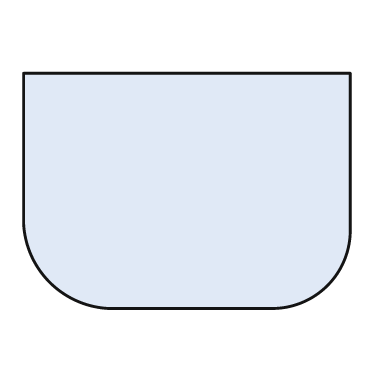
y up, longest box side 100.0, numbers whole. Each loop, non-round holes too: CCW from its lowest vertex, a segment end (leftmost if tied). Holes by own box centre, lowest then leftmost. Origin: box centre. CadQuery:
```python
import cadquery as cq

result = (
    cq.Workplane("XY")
    .moveTo(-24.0, -36.0)
    .lineTo(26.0, -36.0)
    .threePointArc((43.0, -29.0), (50.0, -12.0))
    .lineTo(50.0, 36.0)
    .lineTo(-50.0, 36.0)
    .lineTo(-50.0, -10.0)
    .threePointArc((-42.0, -28.0), (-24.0, -36.0))
    .close()
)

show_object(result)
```